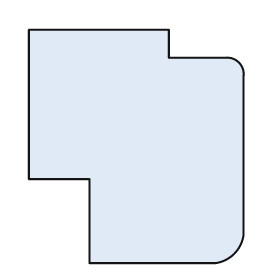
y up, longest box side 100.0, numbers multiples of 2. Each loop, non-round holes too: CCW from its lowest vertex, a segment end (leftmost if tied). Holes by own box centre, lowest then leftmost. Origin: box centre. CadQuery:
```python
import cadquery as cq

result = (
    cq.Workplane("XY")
    .moveTo(-20.0, -50.0)
    .lineTo(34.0, -50.0)
    .threePointArc((42.0, -46.0), (46.0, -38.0))
    .lineTo(46.0, 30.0)
    .threePointArc((44.0, 36.0), (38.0, 38.0))
    .lineTo(14.0, 38.0)
    .lineTo(14.0, 50.0)
    .lineTo(-46.0, 50.0)
    .lineTo(-46.0, -14.0)
    .lineTo(-20.0, -14.0)
    .close()
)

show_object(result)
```